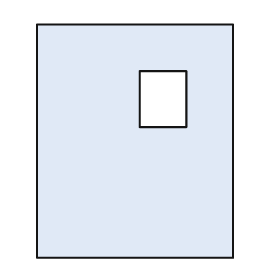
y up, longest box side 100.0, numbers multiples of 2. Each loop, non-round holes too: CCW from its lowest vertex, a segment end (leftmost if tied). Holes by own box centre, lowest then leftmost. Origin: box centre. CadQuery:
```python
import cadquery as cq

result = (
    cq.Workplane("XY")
    .moveTo(-42.0, -50.0)
    .lineTo(42.0, -50.0)
    .lineTo(42.0, 50.0)
    .lineTo(-42.0, 50.0)
    .close()
    .moveTo(2.0, 6.0)
    .lineTo(22.0, 6.0)
    .lineTo(22.0, 30.0)
    .lineTo(2.0, 30.0)
    .close()
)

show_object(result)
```